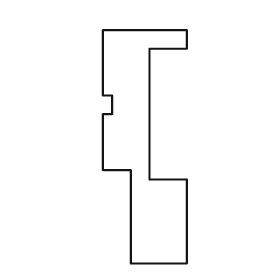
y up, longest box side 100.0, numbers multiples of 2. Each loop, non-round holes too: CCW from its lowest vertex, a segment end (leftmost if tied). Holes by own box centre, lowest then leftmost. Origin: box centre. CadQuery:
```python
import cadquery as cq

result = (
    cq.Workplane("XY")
    .moveTo(-6.0, -50.0)
    .lineTo(18.0, -50.0)
    .lineTo(18.0, -14.0)
    .lineTo(2.0, -14.0)
    .lineTo(2.0, 42.0)
    .lineTo(18.0, 42.0)
    .lineTo(18.0, 50.0)
    .lineTo(-18.0, 50.0)
    .lineTo(-18.0, 22.0)
    .lineTo(-14.0, 22.0)
    .lineTo(-14.0, 14.0)
    .lineTo(-18.0, 14.0)
    .lineTo(-18.0, -10.0)
    .lineTo(-6.0, -10.0)
    .close()
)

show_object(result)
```